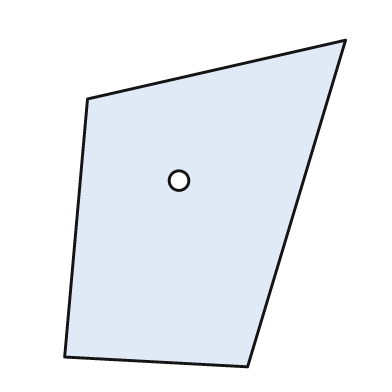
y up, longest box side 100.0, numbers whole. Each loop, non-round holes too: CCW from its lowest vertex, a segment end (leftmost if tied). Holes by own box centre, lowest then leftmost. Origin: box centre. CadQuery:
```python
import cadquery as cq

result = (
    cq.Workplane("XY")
    .moveTo(13.0, -50.0)
    .lineTo(43.0, 50.0)
    .lineTo(-36.0, 32.0)
    .lineTo(-43.0, -47.0)
    .close()
    .moveTo(-8.0, 7.0)
    .circle(3.0)
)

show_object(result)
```